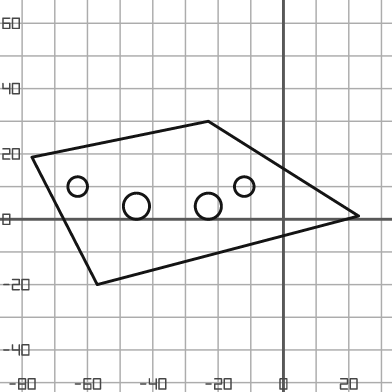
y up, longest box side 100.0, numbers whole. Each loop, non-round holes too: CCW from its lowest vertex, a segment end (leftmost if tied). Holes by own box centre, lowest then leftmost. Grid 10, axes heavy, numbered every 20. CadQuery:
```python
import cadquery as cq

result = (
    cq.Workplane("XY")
    .moveTo(-57.0, -20.0)
    .lineTo(23.0, 1.0)
    .lineTo(-23.0, 30.0)
    .lineTo(-77.0, 19.0)
    .close()
    .moveTo(-45.0, 4.0)
    .circle(4.0)
    .moveTo(-23.0, 4.0)
    .circle(4.0)
    .moveTo(-63.0, 10.0)
    .circle(3.0)
    .moveTo(-12.0, 10.0)
    .circle(3.0)
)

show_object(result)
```